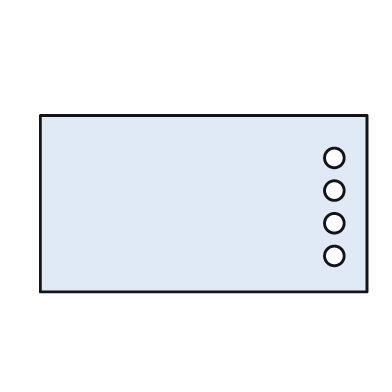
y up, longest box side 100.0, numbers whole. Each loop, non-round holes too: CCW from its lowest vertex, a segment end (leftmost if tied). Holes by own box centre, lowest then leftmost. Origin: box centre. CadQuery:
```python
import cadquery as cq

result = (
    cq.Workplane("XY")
    .moveTo(-50.0, -27.0)
    .lineTo(50.0, -27.0)
    .lineTo(50.0, 27.0)
    .lineTo(-50.0, 27.0)
    .close()
    .moveTo(40.0, -16.0)
    .circle(3.0)
    .moveTo(40.0, -6.0)
    .circle(3.0)
    .moveTo(40.0, 4.0)
    .circle(3.0)
    .moveTo(40.0, 14.0)
    .circle(3.0)
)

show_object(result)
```